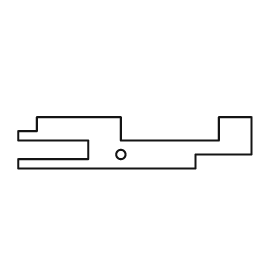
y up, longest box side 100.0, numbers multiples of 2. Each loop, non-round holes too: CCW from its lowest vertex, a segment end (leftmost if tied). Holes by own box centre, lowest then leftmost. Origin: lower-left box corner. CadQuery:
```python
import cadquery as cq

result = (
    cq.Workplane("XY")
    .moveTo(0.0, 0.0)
    .lineTo(76.0, 0.0)
    .lineTo(76.0, 6.0)
    .lineTo(100.0, 6.0)
    .lineTo(100.0, 22.0)
    .lineTo(86.0, 22.0)
    .lineTo(86.0, 12.0)
    .lineTo(44.0, 12.0)
    .lineTo(44.0, 22.0)
    .lineTo(8.0, 22.0)
    .lineTo(8.0, 16.0)
    .lineTo(0.0, 16.0)
    .lineTo(0.0, 12.0)
    .lineTo(30.0, 12.0)
    .lineTo(30.0, 4.0)
    .lineTo(0.0, 4.0)
    .close()
    .moveTo(44.0, 6.0)
    .circle(2.0)
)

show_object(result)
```